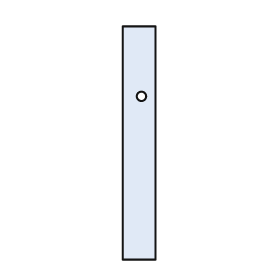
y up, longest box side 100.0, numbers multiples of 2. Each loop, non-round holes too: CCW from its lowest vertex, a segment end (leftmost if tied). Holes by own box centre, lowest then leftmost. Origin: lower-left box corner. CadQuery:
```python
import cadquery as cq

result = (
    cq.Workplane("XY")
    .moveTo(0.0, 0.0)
    .lineTo(14.0, 0.0)
    .lineTo(14.0, 100.0)
    .lineTo(0.0, 100.0)
    .close()
    .moveTo(8.0, 70.0)
    .circle(2.0)
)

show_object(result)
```